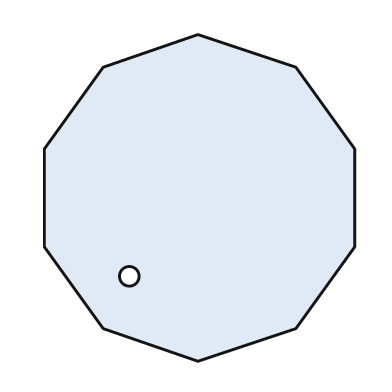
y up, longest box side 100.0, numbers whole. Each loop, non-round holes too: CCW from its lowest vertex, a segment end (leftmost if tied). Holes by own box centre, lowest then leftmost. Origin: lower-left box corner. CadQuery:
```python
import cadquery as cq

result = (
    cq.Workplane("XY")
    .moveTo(47.0, 0.0)
    .lineTo(77.0, 10.0)
    .lineTo(95.0, 35.0)
    .lineTo(95.0, 65.0)
    .lineTo(77.0, 90.0)
    .lineTo(47.0, 100.0)
    .lineTo(18.0, 90.0)
    .lineTo(0.0, 65.0)
    .lineTo(0.0, 35.0)
    .lineTo(18.0, 10.0)
    .close()
    .moveTo(26.0, 26.0)
    .circle(3.0)
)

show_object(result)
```